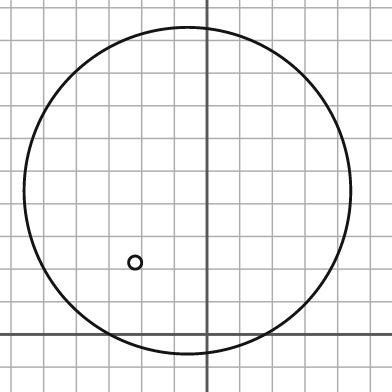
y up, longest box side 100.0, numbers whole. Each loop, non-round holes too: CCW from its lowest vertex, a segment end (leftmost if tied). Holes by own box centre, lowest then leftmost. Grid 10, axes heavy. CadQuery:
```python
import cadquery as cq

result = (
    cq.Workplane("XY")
    .moveTo(-6.0, 44.0)
    .circle(50.0)
    .moveTo(-22.0, 22.0)
    .circle(2.0)
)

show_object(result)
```